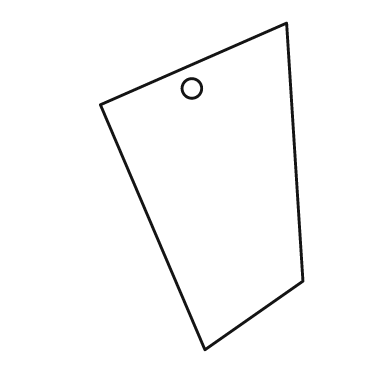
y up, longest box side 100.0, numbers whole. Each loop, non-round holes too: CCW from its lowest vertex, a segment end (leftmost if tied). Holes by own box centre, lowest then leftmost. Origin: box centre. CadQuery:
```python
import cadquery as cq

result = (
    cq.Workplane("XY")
    .moveTo(1.0, -50.0)
    .lineTo(31.0, -29.0)
    .lineTo(26.0, 50.0)
    .lineTo(-31.0, 25.0)
    .close()
    .moveTo(-3.0, 30.0)
    .circle(3.0)
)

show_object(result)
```